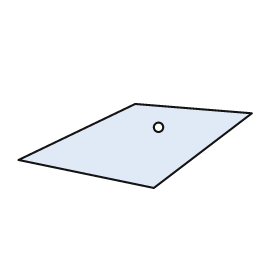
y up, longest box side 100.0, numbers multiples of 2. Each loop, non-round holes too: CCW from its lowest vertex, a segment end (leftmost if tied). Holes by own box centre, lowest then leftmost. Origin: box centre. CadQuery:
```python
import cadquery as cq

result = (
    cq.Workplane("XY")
    .moveTo(8.0, -18.0)
    .lineTo(50.0, 14.0)
    .lineTo(0.0, 18.0)
    .lineTo(-50.0, -6.0)
    .close()
    .moveTo(10.0, 8.0)
    .circle(2.0)
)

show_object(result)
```